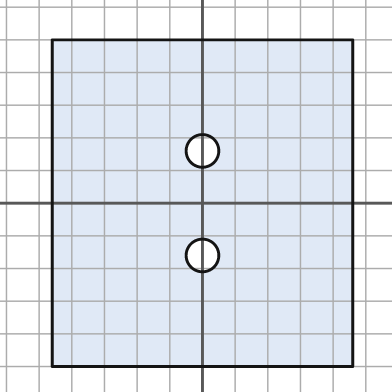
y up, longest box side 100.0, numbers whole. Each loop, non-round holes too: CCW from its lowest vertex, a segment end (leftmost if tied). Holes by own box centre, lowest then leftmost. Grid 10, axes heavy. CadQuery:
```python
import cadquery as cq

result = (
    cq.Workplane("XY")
    .moveTo(-46.0, -50.0)
    .lineTo(46.0, -50.0)
    .lineTo(46.0, 50.0)
    .lineTo(-46.0, 50.0)
    .close()
    .moveTo(0.0, -16.0)
    .circle(5.0)
    .moveTo(0.0, 16.0)
    .circle(5.0)
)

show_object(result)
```